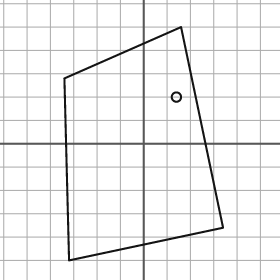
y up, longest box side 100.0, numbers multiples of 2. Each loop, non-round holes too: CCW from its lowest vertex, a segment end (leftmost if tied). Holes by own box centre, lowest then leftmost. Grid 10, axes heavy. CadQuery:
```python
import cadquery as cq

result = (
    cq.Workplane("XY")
    .moveTo(-32.0, -50.0)
    .lineTo(34.0, -36.0)
    .lineTo(16.0, 50.0)
    .lineTo(-34.0, 28.0)
    .close()
    .moveTo(14.0, 20.0)
    .circle(2.0)
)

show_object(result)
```